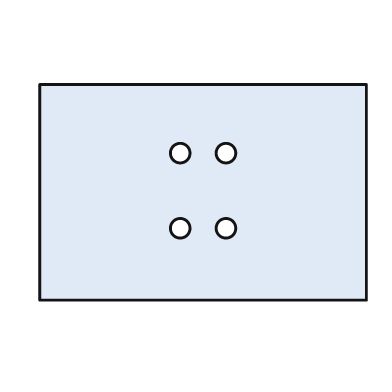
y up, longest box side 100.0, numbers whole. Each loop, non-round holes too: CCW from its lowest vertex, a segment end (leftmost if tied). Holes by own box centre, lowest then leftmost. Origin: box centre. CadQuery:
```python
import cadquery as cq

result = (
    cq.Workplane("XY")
    .moveTo(-50.0, -33.0)
    .lineTo(50.0, -33.0)
    .lineTo(50.0, 33.0)
    .lineTo(-50.0, 33.0)
    .close()
    .moveTo(-7.0, -11.0)
    .circle(3.0)
    .moveTo(7.0, -11.0)
    .circle(3.0)
    .moveTo(-7.0, 12.0)
    .circle(3.0)
    .moveTo(7.0, 12.0)
    .circle(3.0)
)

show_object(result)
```